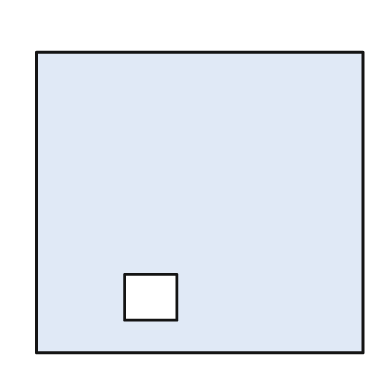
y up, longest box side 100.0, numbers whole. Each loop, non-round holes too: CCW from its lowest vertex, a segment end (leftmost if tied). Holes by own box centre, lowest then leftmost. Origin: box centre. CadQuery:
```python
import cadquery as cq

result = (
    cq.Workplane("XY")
    .moveTo(-50.0, -46.0)
    .lineTo(50.0, -46.0)
    .lineTo(50.0, 46.0)
    .lineTo(-50.0, 46.0)
    .close()
    .moveTo(-23.0, -36.0)
    .lineTo(-7.0, -36.0)
    .lineTo(-7.0, -22.0)
    .lineTo(-23.0, -22.0)
    .close()
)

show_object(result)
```